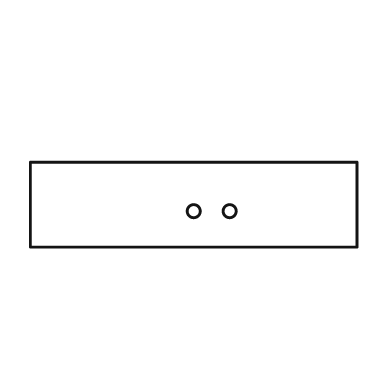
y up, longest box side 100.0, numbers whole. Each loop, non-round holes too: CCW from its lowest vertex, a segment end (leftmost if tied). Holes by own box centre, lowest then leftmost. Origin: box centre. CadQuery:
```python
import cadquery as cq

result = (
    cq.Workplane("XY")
    .moveTo(-50.0, -13.0)
    .lineTo(50.0, -13.0)
    .lineTo(50.0, 13.0)
    .lineTo(-50.0, 13.0)
    .close()
    .moveTo(0.0, -2.0)
    .circle(2.0)
    .moveTo(11.0, -2.0)
    .circle(2.0)
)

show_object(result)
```